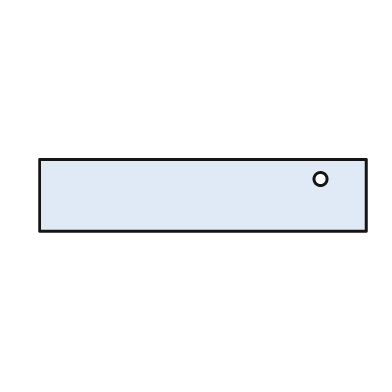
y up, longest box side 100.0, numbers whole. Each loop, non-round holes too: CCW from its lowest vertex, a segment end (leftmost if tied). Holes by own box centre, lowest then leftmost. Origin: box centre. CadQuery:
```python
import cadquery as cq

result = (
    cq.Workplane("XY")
    .moveTo(-50.0, -11.0)
    .lineTo(50.0, -11.0)
    .lineTo(50.0, 11.0)
    .lineTo(-50.0, 11.0)
    .close()
    .moveTo(36.0, 5.0)
    .circle(2.0)
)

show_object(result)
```